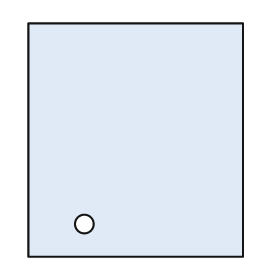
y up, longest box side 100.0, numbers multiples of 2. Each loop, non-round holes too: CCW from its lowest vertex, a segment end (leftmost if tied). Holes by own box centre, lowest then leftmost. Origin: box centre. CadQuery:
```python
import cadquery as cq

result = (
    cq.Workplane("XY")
    .moveTo(-46.0, -50.0)
    .lineTo(46.0, -50.0)
    .lineTo(46.0, 50.0)
    .lineTo(-46.0, 50.0)
    .close()
    .moveTo(-22.0, -36.0)
    .circle(4.0)
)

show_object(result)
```